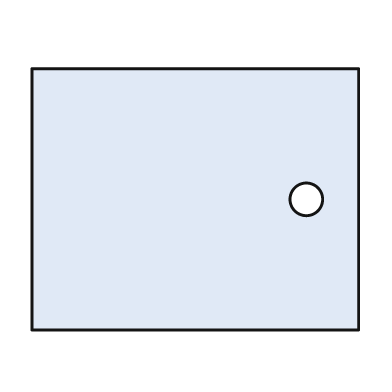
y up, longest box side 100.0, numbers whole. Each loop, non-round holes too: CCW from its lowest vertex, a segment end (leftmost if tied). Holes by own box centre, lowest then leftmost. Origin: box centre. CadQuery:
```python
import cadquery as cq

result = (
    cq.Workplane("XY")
    .moveTo(-50.0, -40.0)
    .lineTo(50.0, -40.0)
    .lineTo(50.0, 40.0)
    .lineTo(-50.0, 40.0)
    .close()
    .moveTo(34.0, 0.0)
    .circle(5.0)
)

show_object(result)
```